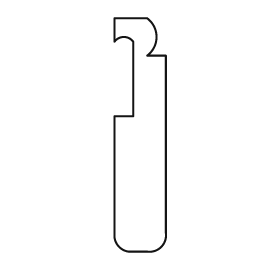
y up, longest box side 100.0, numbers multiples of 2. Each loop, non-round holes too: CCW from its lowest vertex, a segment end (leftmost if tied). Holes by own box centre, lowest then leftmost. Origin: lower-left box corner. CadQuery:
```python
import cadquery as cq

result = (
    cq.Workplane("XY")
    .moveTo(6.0, 0.0)
    .lineTo(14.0, 0.0)
    .threePointArc((20.0, 2.0), (22.0, 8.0))
    .lineTo(22.0, 84.0)
    .lineTo(14.0, 84.0)
    .threePointArc((18.0, 92.0), (14.0, 100.0))
    .lineTo(0.0, 100.0)
    .lineTo(0.0, 90.0)
    .threePointArc((4.0, 92.0), (8.0, 90.0))
    .lineTo(8.0, 58.0)
    .lineTo(0.0, 58.0)
    .lineTo(0.0, 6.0)
    .threePointArc((2.0, 2.0), (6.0, 0.0))
    .close()
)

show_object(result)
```